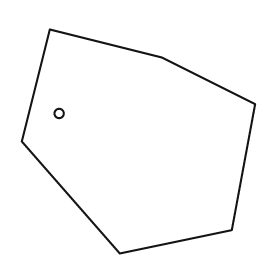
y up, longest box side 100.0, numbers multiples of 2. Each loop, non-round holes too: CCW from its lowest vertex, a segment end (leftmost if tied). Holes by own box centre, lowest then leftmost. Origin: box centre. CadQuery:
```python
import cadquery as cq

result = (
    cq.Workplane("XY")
    .moveTo(-8.0, -48.0)
    .lineTo(40.0, -38.0)
    .lineTo(50.0, 16.0)
    .lineTo(10.0, 36.0)
    .lineTo(-38.0, 48.0)
    .lineTo(-50.0, 0.0)
    .close()
    .moveTo(-34.0, 12.0)
    .circle(2.0)
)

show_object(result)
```